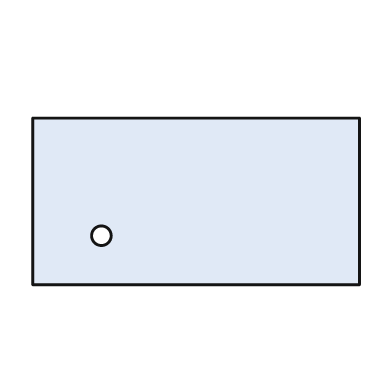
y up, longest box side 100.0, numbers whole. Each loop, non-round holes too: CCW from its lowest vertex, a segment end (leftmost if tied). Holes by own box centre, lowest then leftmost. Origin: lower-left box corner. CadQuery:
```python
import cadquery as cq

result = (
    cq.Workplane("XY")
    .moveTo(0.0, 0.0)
    .lineTo(100.0, 0.0)
    .lineTo(100.0, 51.0)
    .lineTo(0.0, 51.0)
    .close()
    .moveTo(21.0, 15.0)
    .circle(3.0)
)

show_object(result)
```